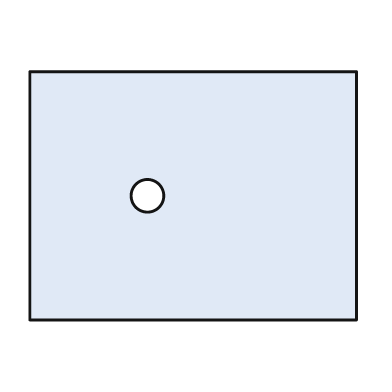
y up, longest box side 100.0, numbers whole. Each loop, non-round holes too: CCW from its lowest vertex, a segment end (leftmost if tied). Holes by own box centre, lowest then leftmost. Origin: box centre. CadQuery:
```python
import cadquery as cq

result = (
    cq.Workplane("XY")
    .moveTo(-50.0, -38.0)
    .lineTo(50.0, -38.0)
    .lineTo(50.0, 38.0)
    .lineTo(-50.0, 38.0)
    .close()
    .moveTo(-14.0, 0.0)
    .circle(5.0)
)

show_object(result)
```